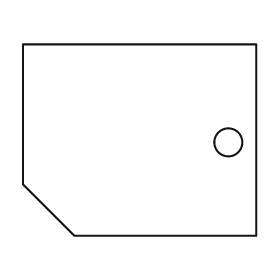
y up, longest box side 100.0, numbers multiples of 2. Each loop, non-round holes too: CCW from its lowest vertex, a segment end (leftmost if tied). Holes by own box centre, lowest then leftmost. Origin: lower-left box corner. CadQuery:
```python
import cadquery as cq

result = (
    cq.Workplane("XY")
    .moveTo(22.0, 0.0)
    .lineTo(100.0, 0.0)
    .lineTo(100.0, 82.0)
    .lineTo(0.0, 82.0)
    .lineTo(0.0, 22.0)
    .close()
    .moveTo(88.0, 40.0)
    .circle(6.0)
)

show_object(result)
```